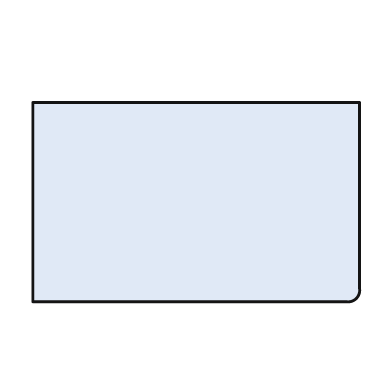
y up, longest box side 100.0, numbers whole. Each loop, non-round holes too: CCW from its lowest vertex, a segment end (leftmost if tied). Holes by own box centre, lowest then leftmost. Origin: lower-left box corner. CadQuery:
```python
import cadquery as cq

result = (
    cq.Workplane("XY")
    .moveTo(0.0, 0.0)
    .lineTo(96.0, 0.0)
    .threePointArc((99.0, 1.0), (100.0, 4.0))
    .lineTo(100.0, 61.0)
    .lineTo(0.0, 61.0)
    .close()
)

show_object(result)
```